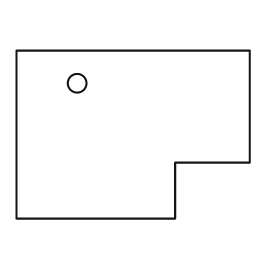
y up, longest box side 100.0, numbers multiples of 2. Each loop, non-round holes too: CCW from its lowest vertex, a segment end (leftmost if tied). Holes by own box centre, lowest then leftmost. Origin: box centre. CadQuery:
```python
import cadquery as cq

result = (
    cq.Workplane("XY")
    .moveTo(-50.0, -36.0)
    .lineTo(18.0, -36.0)
    .lineTo(18.0, -12.0)
    .lineTo(50.0, -12.0)
    .lineTo(50.0, 36.0)
    .lineTo(-50.0, 36.0)
    .close()
    .moveTo(-24.0, 22.0)
    .circle(4.0)
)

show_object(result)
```